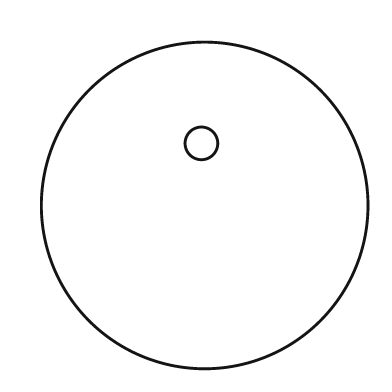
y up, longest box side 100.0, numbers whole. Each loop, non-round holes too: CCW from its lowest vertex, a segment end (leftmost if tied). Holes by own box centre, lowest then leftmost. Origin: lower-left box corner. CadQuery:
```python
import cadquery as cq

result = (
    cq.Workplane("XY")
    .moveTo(50.0, 50.0)
    .circle(50.0)
    .moveTo(49.0, 69.0)
    .circle(5.0)
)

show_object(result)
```